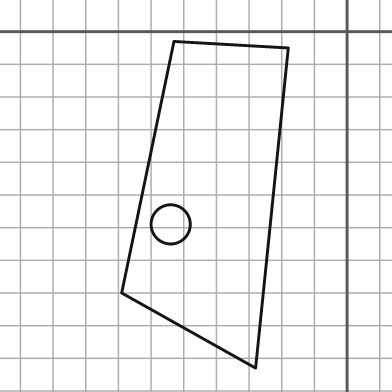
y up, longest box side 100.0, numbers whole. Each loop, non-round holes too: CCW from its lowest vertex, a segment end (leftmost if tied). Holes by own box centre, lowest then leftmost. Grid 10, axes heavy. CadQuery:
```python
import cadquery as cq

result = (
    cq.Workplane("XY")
    .moveTo(-28.0, -103.0)
    .lineTo(-18.0, -5.0)
    .lineTo(-53.0, -3.0)
    .lineTo(-69.0, -80.0)
    .close()
    .moveTo(-54.0, -59.0)
    .circle(6.0)
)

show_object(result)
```